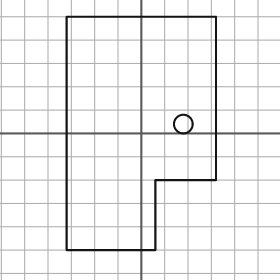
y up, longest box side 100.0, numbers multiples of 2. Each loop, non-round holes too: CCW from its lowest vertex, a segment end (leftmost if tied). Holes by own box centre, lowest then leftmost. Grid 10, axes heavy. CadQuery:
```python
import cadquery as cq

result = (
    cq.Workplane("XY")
    .moveTo(-32.0, -50.0)
    .lineTo(6.0, -50.0)
    .lineTo(6.0, -20.0)
    .lineTo(32.0, -20.0)
    .lineTo(32.0, 50.0)
    .lineTo(-32.0, 50.0)
    .close()
    .moveTo(18.0, 4.0)
    .circle(4.0)
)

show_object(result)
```